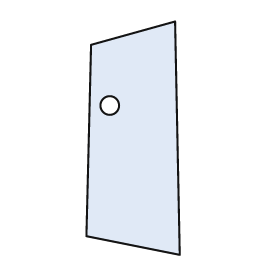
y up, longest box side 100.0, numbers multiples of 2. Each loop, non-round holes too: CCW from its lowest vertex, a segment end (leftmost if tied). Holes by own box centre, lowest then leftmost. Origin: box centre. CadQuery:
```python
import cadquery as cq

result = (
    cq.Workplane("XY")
    .moveTo(20.0, -50.0)
    .lineTo(18.0, 50.0)
    .lineTo(-18.0, 40.0)
    .lineTo(-20.0, -42.0)
    .close()
    .moveTo(-10.0, 14.0)
    .circle(4.0)
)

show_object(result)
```